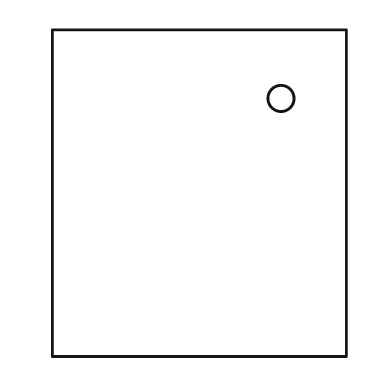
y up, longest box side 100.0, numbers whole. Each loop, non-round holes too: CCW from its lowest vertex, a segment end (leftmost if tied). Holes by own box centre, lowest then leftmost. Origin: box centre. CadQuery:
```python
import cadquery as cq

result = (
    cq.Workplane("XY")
    .moveTo(-45.0, -50.0)
    .lineTo(45.0, -50.0)
    .lineTo(45.0, 50.0)
    .lineTo(-45.0, 50.0)
    .close()
    .moveTo(25.0, 29.0)
    .circle(4.0)
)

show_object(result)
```